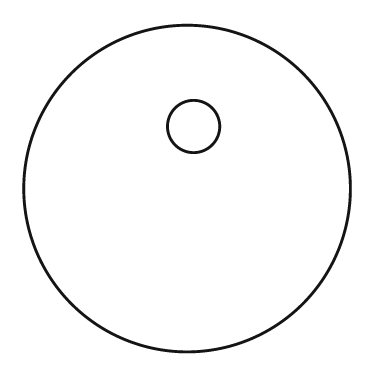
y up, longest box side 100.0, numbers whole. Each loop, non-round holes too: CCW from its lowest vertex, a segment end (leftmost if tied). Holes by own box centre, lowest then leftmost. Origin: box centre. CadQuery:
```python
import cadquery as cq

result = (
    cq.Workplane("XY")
    .moveTo(0.0, 0.0)
    .circle(50.0)
    .moveTo(2.0, 19.0)
    .circle(8.0)
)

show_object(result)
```